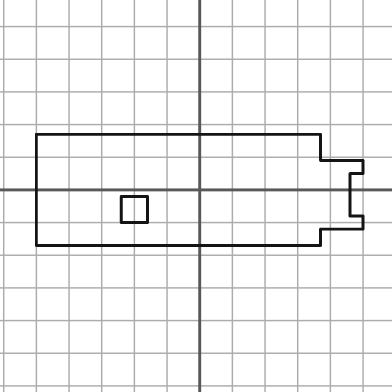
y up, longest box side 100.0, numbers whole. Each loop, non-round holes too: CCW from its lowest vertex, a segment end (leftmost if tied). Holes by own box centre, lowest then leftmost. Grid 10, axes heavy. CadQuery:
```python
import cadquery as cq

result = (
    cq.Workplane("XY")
    .moveTo(-50.0, -17.0)
    .lineTo(37.0, -17.0)
    .lineTo(37.0, -12.0)
    .lineTo(50.0, -12.0)
    .lineTo(50.0, -8.0)
    .lineTo(46.0, -8.0)
    .lineTo(46.0, 5.0)
    .lineTo(50.0, 5.0)
    .lineTo(50.0, 9.0)
    .lineTo(37.0, 9.0)
    .lineTo(37.0, 17.0)
    .lineTo(-50.0, 17.0)
    .close()
    .moveTo(-24.0, -10.0)
    .lineTo(-16.0, -10.0)
    .lineTo(-16.0, -2.0)
    .lineTo(-24.0, -2.0)
    .close()
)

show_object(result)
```